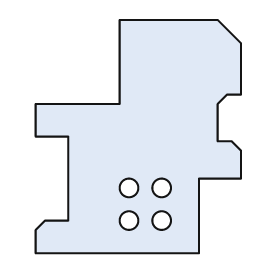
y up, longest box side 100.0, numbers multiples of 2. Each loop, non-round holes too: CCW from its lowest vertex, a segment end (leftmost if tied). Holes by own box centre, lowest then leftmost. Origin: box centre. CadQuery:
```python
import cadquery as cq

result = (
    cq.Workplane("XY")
    .moveTo(-44.0, -50.0)
    .lineTo(26.0, -50.0)
    .lineTo(26.0, -18.0)
    .lineTo(44.0, -18.0)
    .lineTo(44.0, -6.0)
    .lineTo(40.0, -2.0)
    .lineTo(34.0, -2.0)
    .lineTo(34.0, 14.0)
    .lineTo(38.0, 18.0)
    .lineTo(44.0, 18.0)
    .lineTo(44.0, 40.0)
    .lineTo(34.0, 50.0)
    .lineTo(-8.0, 50.0)
    .lineTo(-8.0, 14.0)
    .lineTo(-44.0, 14.0)
    .lineTo(-44.0, 0.0)
    .lineTo(-30.0, 0.0)
    .lineTo(-30.0, -36.0)
    .lineTo(-40.0, -36.0)
    .lineTo(-44.0, -40.0)
    .close()
    .moveTo(-4.0, -36.0)
    .circle(4.0)
    .moveTo(10.0, -36.0)
    .circle(4.0)
    .moveTo(-4.0, -22.0)
    .circle(4.0)
    .moveTo(10.0, -22.0)
    .circle(4.0)
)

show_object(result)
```